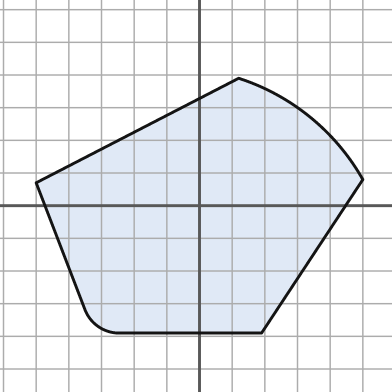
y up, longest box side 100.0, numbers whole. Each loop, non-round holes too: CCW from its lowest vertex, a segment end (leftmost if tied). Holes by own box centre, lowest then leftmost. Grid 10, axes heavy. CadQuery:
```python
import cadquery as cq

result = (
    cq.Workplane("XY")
    .moveTo(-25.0, -39.0)
    .lineTo(19.0, -39.0)
    .lineTo(50.0, 8.0)
    .threePointArc((34.0, 27.0), (12.0, 39.0))
    .lineTo(-50.0, 7.0)
    .lineTo(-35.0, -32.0)
    .threePointArc((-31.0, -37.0), (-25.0, -39.0))
    .close()
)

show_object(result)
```